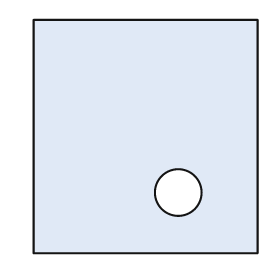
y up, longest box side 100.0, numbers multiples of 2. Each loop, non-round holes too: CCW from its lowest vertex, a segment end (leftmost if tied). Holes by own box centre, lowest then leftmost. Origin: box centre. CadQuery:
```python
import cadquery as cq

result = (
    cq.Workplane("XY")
    .moveTo(-48.0, -50.0)
    .lineTo(48.0, -50.0)
    .lineTo(48.0, 50.0)
    .lineTo(-48.0, 50.0)
    .close()
    .moveTo(14.0, -24.0)
    .circle(10.0)
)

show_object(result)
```